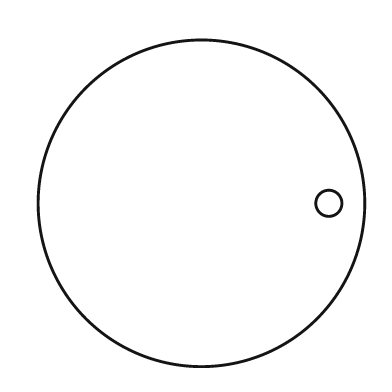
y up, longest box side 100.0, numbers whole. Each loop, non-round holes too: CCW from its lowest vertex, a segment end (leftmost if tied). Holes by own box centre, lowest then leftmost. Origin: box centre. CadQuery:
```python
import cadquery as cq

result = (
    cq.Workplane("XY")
    .moveTo(0.0, 0.0)
    .circle(50.0)
    .moveTo(39.0, 0.0)
    .circle(4.0)
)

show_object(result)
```